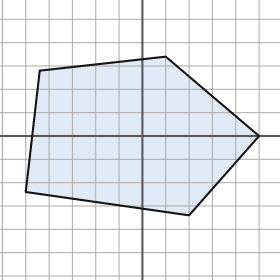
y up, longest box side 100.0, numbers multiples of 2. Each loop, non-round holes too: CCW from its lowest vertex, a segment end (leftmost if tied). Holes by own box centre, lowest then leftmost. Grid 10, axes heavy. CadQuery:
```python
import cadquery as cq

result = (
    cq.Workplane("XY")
    .moveTo(20.0, -34.0)
    .lineTo(50.0, 0.0)
    .lineTo(10.0, 34.0)
    .lineTo(-44.0, 28.0)
    .lineTo(-50.0, -24.0)
    .close()
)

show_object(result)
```